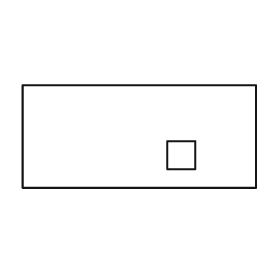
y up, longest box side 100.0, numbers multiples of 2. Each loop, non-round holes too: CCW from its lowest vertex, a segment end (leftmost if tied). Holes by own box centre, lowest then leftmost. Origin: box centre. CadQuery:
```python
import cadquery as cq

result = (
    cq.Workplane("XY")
    .moveTo(-50.0, -22.0)
    .lineTo(50.0, -22.0)
    .lineTo(50.0, 22.0)
    .lineTo(-50.0, 22.0)
    .close()
    .moveTo(12.0, -14.0)
    .lineTo(24.0, -14.0)
    .lineTo(24.0, -2.0)
    .lineTo(12.0, -2.0)
    .close()
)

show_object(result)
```